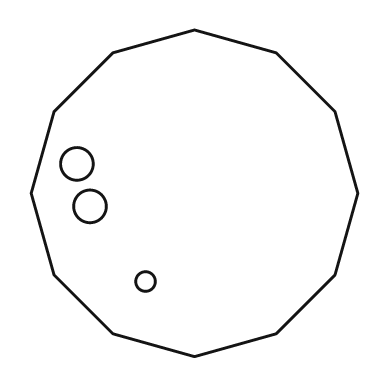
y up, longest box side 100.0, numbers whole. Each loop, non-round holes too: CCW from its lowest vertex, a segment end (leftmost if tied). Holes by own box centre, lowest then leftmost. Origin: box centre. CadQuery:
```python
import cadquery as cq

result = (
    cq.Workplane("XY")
    .moveTo(0.0, -50.0)
    .lineTo(25.0, -43.0)
    .lineTo(43.0, -25.0)
    .lineTo(50.0, 0.0)
    .lineTo(43.0, 25.0)
    .lineTo(25.0, 43.0)
    .lineTo(0.0, 50.0)
    .lineTo(-25.0, 43.0)
    .lineTo(-43.0, 25.0)
    .lineTo(-50.0, 0.0)
    .lineTo(-43.0, -25.0)
    .lineTo(-25.0, -43.0)
    .close()
    .moveTo(-15.0, -27.0)
    .circle(3.0)
    .moveTo(-32.0, -4.0)
    .circle(5.0)
    .moveTo(-36.0, 9.0)
    .circle(5.0)
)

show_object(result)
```